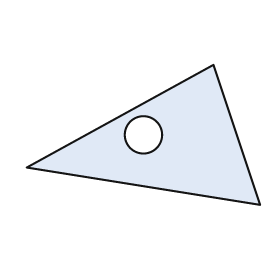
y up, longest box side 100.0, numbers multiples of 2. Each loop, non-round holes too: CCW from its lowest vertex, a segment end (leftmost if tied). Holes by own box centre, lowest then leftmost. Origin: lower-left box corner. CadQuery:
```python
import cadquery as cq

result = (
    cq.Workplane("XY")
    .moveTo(100.0, 0.0)
    .lineTo(80.0, 60.0)
    .lineTo(0.0, 16.0)
    .close()
    .moveTo(50.0, 30.0)
    .circle(8.0)
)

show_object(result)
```